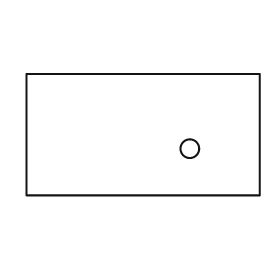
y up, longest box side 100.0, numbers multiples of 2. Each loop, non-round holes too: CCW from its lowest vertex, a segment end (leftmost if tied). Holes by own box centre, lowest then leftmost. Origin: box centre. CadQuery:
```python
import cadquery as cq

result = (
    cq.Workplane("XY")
    .moveTo(-50.0, -26.0)
    .lineTo(50.0, -26.0)
    .lineTo(50.0, 26.0)
    .lineTo(-50.0, 26.0)
    .close()
    .moveTo(20.0, -6.0)
    .circle(4.0)
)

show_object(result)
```